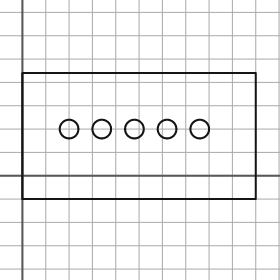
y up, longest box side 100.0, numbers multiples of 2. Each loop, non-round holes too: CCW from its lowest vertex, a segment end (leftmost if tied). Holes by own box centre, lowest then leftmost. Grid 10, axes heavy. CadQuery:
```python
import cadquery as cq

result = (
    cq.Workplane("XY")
    .moveTo(0.0, -10.0)
    .lineTo(100.0, -10.0)
    .lineTo(100.0, 44.0)
    .lineTo(0.0, 44.0)
    .close()
    .moveTo(20.0, 20.0)
    .circle(4.0)
    .moveTo(34.0, 20.0)
    .circle(4.0)
    .moveTo(48.0, 20.0)
    .circle(4.0)
    .moveTo(62.0, 20.0)
    .circle(4.0)
    .moveTo(76.0, 20.0)
    .circle(4.0)
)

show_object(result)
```